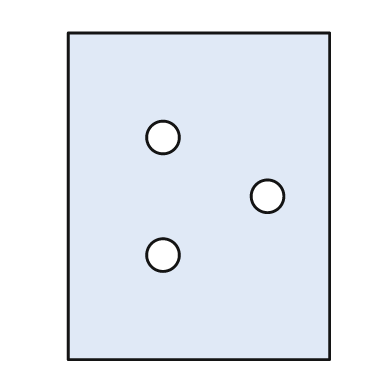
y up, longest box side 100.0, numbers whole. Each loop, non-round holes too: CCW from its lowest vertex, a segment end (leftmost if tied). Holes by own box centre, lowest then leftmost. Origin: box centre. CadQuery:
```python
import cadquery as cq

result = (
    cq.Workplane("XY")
    .moveTo(-40.0, -50.0)
    .lineTo(40.0, -50.0)
    .lineTo(40.0, 50.0)
    .lineTo(-40.0, 50.0)
    .close()
    .moveTo(-11.0, -18.0)
    .circle(5.0)
    .moveTo(21.0, 0.0)
    .circle(5.0)
    .moveTo(-11.0, 18.0)
    .circle(5.0)
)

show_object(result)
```